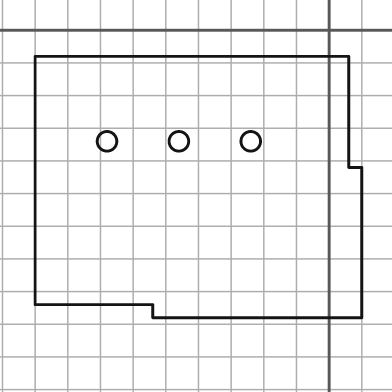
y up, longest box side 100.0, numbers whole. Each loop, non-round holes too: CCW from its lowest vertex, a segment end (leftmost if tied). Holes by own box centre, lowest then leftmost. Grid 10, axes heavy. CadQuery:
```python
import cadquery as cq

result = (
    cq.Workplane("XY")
    .moveTo(-54.0, -88.0)
    .lineTo(10.0, -88.0)
    .lineTo(10.0, -42.0)
    .lineTo(6.0, -42.0)
    .lineTo(6.0, -8.0)
    .lineTo(-90.0, -8.0)
    .lineTo(-90.0, -84.0)
    .lineTo(-54.0, -84.0)
    .close()
    .moveTo(-68.0, -34.0)
    .circle(3.0)
    .moveTo(-46.0, -34.0)
    .circle(3.0)
    .moveTo(-24.0, -34.0)
    .circle(3.0)
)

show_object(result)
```